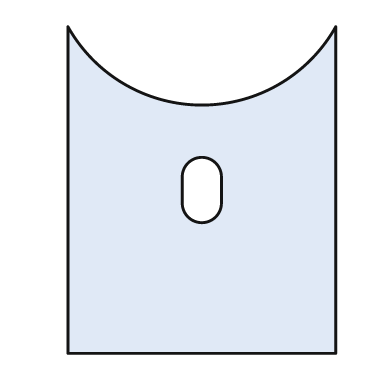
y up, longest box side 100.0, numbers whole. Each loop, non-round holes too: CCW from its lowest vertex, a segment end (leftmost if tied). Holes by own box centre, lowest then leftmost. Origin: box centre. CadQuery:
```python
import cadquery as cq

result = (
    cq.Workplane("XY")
    .moveTo(-41.0, -50.0)
    .lineTo(41.0, -50.0)
    .lineTo(41.0, 50.0)
    .threePointArc((0.0, 26.0), (-41.0, 50.0))
    .close()
    .moveTo(-6.0, -4.0)
    .threePointArc((0.0, -10.0), (6.0, -4.0))
    .lineTo(6.0, 4.0)
    .threePointArc((0.0, 10.0), (-6.0, 4.0))
    .close()
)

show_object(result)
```